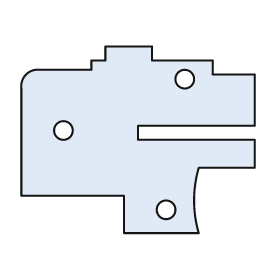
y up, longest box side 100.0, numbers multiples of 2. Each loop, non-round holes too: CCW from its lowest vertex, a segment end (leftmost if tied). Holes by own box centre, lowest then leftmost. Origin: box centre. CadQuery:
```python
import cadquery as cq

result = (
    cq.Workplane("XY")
    .moveTo(-6.0, -40.0)
    .lineTo(26.0, -40.0)
    .threePointArc((24.0, -26.0), (26.0, -12.0))
    .lineTo(50.0, -12.0)
    .lineTo(50.0, 0.0)
    .lineTo(0.0, 0.0)
    .lineTo(0.0, 6.0)
    .lineTo(50.0, 6.0)
    .lineTo(50.0, 28.0)
    .lineTo(32.0, 28.0)
    .lineTo(32.0, 34.0)
    .lineTo(6.0, 34.0)
    .lineTo(6.0, 40.0)
    .lineTo(-14.0, 40.0)
    .lineTo(-14.0, 34.0)
    .lineTo(-20.0, 34.0)
    .lineTo(-20.0, 30.0)
    .lineTo(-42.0, 30.0)
    .threePointArc((-48.0, 28.0), (-50.0, 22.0))
    .lineTo(-50.0, -24.0)
    .lineTo(-6.0, -24.0)
    .close()
    .moveTo(12.0, -30.0)
    .circle(4.0)
    .moveTo(-32.0, 4.0)
    .circle(4.0)
    .moveTo(20.0, 26.0)
    .circle(4.0)
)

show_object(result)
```